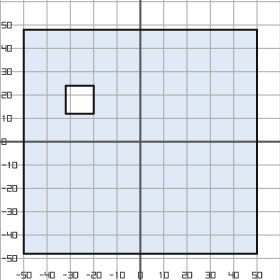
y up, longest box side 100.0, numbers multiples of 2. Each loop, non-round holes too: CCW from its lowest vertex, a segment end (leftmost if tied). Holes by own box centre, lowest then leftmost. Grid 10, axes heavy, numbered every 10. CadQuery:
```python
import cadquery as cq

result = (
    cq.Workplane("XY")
    .moveTo(-50.0, -48.0)
    .lineTo(50.0, -48.0)
    .lineTo(50.0, 48.0)
    .lineTo(-50.0, 48.0)
    .close()
    .moveTo(-32.0, 12.0)
    .lineTo(-20.0, 12.0)
    .lineTo(-20.0, 24.0)
    .lineTo(-32.0, 24.0)
    .close()
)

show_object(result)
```